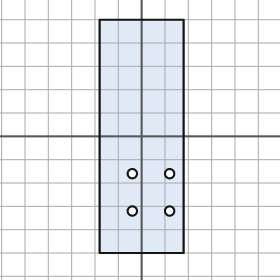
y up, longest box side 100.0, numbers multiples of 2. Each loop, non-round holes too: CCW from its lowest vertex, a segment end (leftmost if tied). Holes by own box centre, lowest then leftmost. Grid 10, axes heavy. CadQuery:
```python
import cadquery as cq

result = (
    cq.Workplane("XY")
    .moveTo(-18.0, -50.0)
    .lineTo(18.0, -50.0)
    .lineTo(18.0, 50.0)
    .lineTo(-18.0, 50.0)
    .close()
    .moveTo(-4.0, -32.0)
    .circle(2.0)
    .moveTo(12.0, -32.0)
    .circle(2.0)
    .moveTo(-4.0, -16.0)
    .circle(2.0)
    .moveTo(12.0, -16.0)
    .circle(2.0)
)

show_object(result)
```